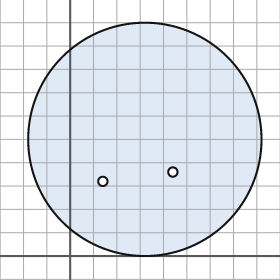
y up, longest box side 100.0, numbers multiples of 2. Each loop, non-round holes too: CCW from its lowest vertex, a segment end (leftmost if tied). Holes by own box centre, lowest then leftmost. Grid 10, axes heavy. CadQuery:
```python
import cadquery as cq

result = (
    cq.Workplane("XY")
    .moveTo(32.0, 50.0)
    .circle(50.0)
    .moveTo(14.0, 32.0)
    .circle(2.0)
    .moveTo(44.0, 36.0)
    .circle(2.0)
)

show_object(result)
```